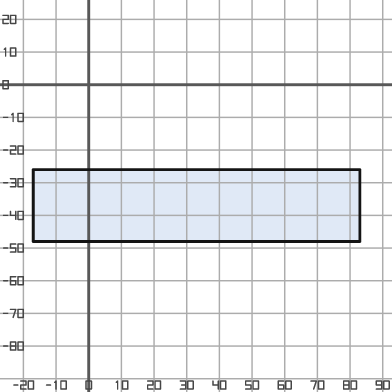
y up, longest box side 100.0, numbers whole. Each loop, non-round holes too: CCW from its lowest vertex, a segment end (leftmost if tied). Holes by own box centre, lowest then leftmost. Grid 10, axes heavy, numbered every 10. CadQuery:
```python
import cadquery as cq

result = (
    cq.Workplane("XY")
    .moveTo(-17.0, -48.0)
    .lineTo(83.0, -48.0)
    .lineTo(83.0, -26.0)
    .lineTo(-17.0, -26.0)
    .close()
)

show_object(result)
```